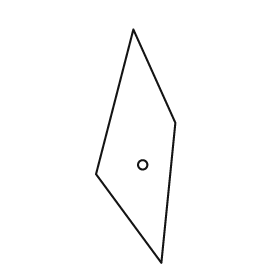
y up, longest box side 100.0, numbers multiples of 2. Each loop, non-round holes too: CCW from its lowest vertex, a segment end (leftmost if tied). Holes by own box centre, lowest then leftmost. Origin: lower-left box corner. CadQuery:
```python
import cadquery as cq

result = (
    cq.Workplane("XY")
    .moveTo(28.0, 0.0)
    .lineTo(34.0, 60.0)
    .lineTo(16.0, 100.0)
    .lineTo(0.0, 38.0)
    .close()
    .moveTo(20.0, 42.0)
    .circle(2.0)
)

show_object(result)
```